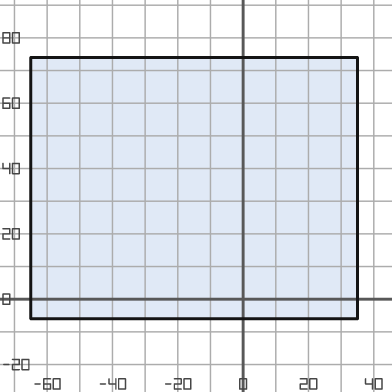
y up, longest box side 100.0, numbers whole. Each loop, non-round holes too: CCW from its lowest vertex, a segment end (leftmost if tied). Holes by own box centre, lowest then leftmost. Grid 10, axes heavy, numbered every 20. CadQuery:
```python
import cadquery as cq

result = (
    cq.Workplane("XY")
    .moveTo(-65.0, -6.0)
    .lineTo(35.0, -6.0)
    .lineTo(35.0, 74.0)
    .lineTo(-65.0, 74.0)
    .close()
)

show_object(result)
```